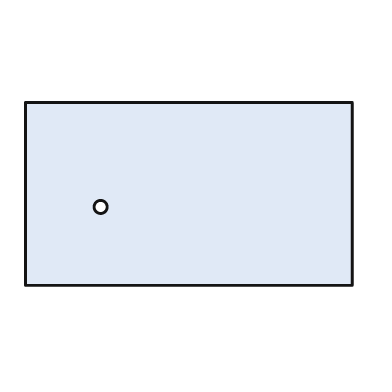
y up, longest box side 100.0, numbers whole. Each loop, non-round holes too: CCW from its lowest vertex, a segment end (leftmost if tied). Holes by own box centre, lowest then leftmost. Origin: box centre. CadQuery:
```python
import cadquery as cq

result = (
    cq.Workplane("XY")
    .moveTo(-50.0, -28.0)
    .lineTo(50.0, -28.0)
    .lineTo(50.0, 28.0)
    .lineTo(-50.0, 28.0)
    .close()
    .moveTo(-27.0, -4.0)
    .circle(2.0)
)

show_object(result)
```